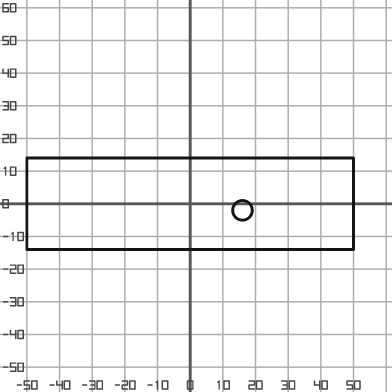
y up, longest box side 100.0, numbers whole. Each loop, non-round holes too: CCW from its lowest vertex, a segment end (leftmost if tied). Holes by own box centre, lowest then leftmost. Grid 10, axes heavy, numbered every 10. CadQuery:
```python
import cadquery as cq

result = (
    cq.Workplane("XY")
    .moveTo(-50.0, -14.0)
    .lineTo(50.0, -14.0)
    .lineTo(50.0, 14.0)
    .lineTo(-50.0, 14.0)
    .close()
    .moveTo(16.0, -2.0)
    .circle(3.0)
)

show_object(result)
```